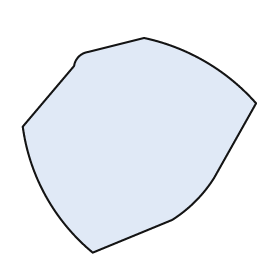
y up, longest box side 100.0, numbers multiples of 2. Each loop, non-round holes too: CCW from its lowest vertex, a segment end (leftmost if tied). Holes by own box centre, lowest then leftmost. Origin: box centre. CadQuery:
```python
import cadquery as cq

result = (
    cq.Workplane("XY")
    .moveTo(-20.0, -46.0)
    .lineTo(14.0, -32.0)
    .threePointArc((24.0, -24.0), (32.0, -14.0))
    .lineTo(50.0, 18.0)
    .threePointArc((28.0, 36.0), (2.0, 46.0))
    .lineTo(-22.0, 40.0)
    .threePointArc((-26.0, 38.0), (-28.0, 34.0))
    .lineTo(-50.0, 8.0)
    .threePointArc((-40.0, -22.0), (-20.0, -46.0))
    .close()
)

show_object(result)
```